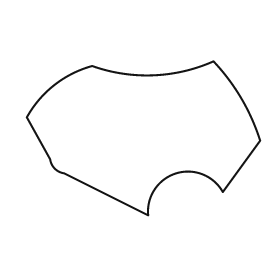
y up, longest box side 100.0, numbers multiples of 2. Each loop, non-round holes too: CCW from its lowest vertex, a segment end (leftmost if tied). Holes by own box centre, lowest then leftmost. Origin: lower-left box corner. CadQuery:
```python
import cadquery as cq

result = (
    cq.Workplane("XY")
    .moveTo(52.0, 0.0)
    .threePointArc((64.0, 18.0), (84.0, 10.0))
    .lineTo(100.0, 32.0)
    .threePointArc((92.0, 50.0), (80.0, 66.0))
    .threePointArc((54.0, 60.0), (28.0, 64.0))
    .threePointArc((12.0, 56.0), (0.0, 42.0))
    .lineTo(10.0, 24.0)
    .threePointArc((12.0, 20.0), (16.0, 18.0))
    .close()
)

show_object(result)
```